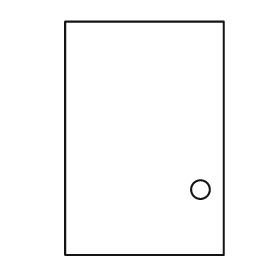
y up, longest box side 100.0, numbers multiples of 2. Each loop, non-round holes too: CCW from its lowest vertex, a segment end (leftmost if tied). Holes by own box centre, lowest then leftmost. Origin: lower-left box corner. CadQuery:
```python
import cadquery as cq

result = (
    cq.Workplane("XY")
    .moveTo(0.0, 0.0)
    .lineTo(68.0, 0.0)
    .lineTo(68.0, 100.0)
    .lineTo(0.0, 100.0)
    .close()
    .moveTo(58.0, 28.0)
    .circle(4.0)
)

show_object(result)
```